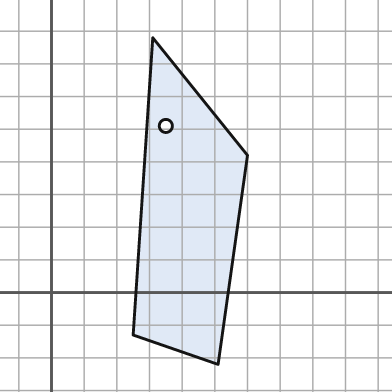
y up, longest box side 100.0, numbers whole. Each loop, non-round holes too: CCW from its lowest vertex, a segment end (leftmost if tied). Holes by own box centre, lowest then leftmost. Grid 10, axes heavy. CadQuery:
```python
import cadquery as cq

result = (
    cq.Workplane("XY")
    .moveTo(51.0, -22.0)
    .lineTo(60.0, 42.0)
    .lineTo(31.0, 78.0)
    .lineTo(25.0, -13.0)
    .close()
    .moveTo(35.0, 51.0)
    .circle(2.0)
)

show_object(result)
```